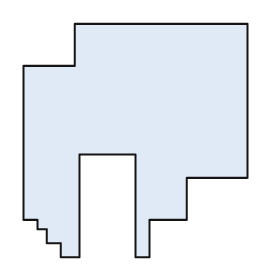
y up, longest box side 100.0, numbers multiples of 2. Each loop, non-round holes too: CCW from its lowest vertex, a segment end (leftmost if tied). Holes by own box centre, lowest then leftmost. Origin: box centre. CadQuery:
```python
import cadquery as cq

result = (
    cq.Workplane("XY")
    .moveTo(-32.0, -50.0)
    .lineTo(-24.0, -50.0)
    .lineTo(-24.0, -6.0)
    .lineTo(0.0, -6.0)
    .lineTo(0.0, -50.0)
    .lineTo(6.0, -50.0)
    .lineTo(6.0, -34.0)
    .lineTo(22.0, -34.0)
    .lineTo(22.0, -16.0)
    .lineTo(48.0, -16.0)
    .lineTo(48.0, 50.0)
    .lineTo(-26.0, 50.0)
    .lineTo(-26.0, 32.0)
    .lineTo(-48.0, 32.0)
    .lineTo(-48.0, -34.0)
    .lineTo(-42.0, -34.0)
    .lineTo(-42.0, -38.0)
    .lineTo(-38.0, -38.0)
    .lineTo(-38.0, -44.0)
    .lineTo(-32.0, -44.0)
    .close()
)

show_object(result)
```